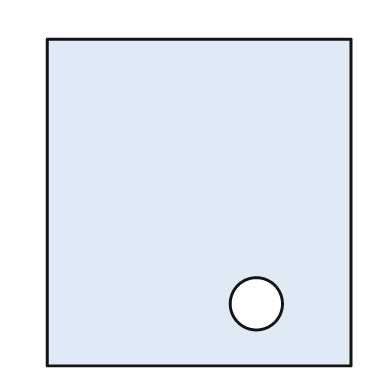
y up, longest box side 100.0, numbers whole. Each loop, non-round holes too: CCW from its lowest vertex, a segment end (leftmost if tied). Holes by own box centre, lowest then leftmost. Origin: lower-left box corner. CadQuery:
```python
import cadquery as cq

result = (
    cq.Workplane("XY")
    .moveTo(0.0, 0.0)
    .lineTo(93.0, 0.0)
    .lineTo(93.0, 100.0)
    .lineTo(0.0, 100.0)
    .close()
    .moveTo(64.0, 19.0)
    .circle(8.0)
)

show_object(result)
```